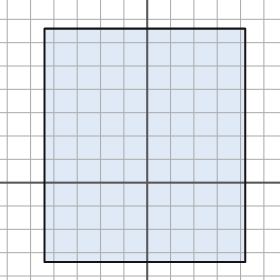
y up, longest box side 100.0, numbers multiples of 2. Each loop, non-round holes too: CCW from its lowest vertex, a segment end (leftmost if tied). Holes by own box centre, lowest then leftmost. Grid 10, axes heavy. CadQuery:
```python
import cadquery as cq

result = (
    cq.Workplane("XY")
    .moveTo(-44.0, -34.0)
    .lineTo(42.0, -34.0)
    .lineTo(42.0, 66.0)
    .lineTo(-44.0, 66.0)
    .close()
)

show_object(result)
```